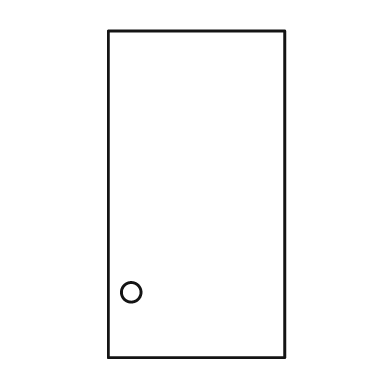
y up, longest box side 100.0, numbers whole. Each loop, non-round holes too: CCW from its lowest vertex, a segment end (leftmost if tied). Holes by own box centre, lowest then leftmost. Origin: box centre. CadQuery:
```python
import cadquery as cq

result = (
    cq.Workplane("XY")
    .moveTo(-27.0, -50.0)
    .lineTo(27.0, -50.0)
    .lineTo(27.0, 50.0)
    .lineTo(-27.0, 50.0)
    .close()
    .moveTo(-20.0, -30.0)
    .circle(3.0)
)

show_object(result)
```